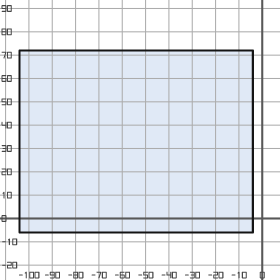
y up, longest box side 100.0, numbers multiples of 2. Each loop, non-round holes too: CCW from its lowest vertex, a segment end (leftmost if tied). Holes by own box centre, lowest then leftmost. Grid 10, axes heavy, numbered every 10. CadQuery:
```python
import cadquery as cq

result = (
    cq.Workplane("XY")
    .moveTo(-104.0, -6.0)
    .lineTo(-4.0, -6.0)
    .lineTo(-4.0, 72.0)
    .lineTo(-104.0, 72.0)
    .close()
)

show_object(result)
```